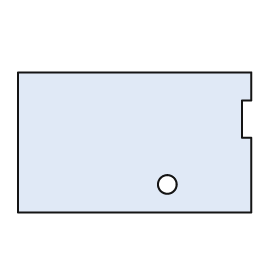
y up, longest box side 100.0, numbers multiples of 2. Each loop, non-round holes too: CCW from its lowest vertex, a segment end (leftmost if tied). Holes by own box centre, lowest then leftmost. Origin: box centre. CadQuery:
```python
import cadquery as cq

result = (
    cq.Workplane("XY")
    .moveTo(-50.0, -30.0)
    .lineTo(50.0, -30.0)
    .lineTo(50.0, 2.0)
    .lineTo(46.0, 2.0)
    .lineTo(46.0, 18.0)
    .lineTo(50.0, 18.0)
    .lineTo(50.0, 30.0)
    .lineTo(-50.0, 30.0)
    .close()
    .moveTo(14.0, -18.0)
    .circle(4.0)
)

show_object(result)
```